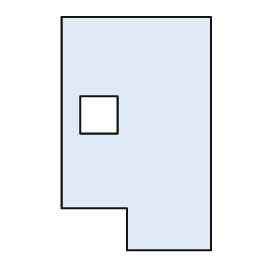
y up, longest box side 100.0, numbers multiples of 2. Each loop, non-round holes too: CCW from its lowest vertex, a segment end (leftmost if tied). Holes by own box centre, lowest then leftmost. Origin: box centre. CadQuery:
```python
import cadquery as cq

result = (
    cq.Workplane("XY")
    .moveTo(-4.0, -50.0)
    .lineTo(32.0, -50.0)
    .lineTo(32.0, 50.0)
    .lineTo(-32.0, 50.0)
    .lineTo(-32.0, -32.0)
    .lineTo(-4.0, -32.0)
    .close()
    .moveTo(-24.0, 0.0)
    .lineTo(-8.0, 0.0)
    .lineTo(-8.0, 16.0)
    .lineTo(-24.0, 16.0)
    .close()
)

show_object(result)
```